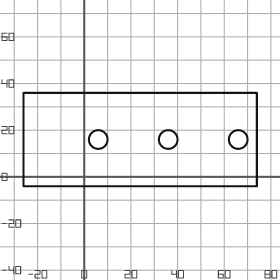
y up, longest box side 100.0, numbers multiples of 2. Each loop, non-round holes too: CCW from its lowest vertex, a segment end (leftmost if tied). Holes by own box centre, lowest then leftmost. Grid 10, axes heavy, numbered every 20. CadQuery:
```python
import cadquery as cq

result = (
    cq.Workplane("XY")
    .moveTo(-26.0, -4.0)
    .lineTo(74.0, -4.0)
    .lineTo(74.0, 36.0)
    .lineTo(-26.0, 36.0)
    .close()
    .moveTo(6.0, 16.0)
    .circle(4.0)
    .moveTo(36.0, 16.0)
    .circle(4.0)
    .moveTo(66.0, 16.0)
    .circle(4.0)
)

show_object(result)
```